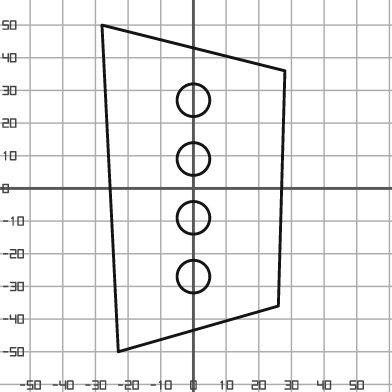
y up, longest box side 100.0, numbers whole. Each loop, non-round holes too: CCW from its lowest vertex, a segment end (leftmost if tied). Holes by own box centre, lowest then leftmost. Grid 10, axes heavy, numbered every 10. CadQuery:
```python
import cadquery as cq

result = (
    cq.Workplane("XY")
    .moveTo(-23.0, -50.0)
    .lineTo(26.0, -36.0)
    .lineTo(28.0, 36.0)
    .lineTo(-28.0, 50.0)
    .close()
    .moveTo(0.0, -27.0)
    .circle(5.0)
    .moveTo(0.0, -9.0)
    .circle(5.0)
    .moveTo(0.0, 9.0)
    .circle(5.0)
    .moveTo(0.0, 27.0)
    .circle(5.0)
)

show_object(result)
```